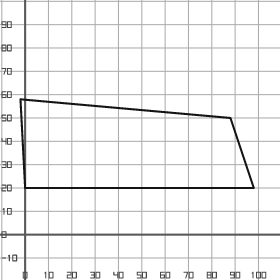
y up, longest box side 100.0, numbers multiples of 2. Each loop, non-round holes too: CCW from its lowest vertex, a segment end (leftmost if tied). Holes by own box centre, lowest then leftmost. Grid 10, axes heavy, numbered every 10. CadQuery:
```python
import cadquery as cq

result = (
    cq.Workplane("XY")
    .moveTo(0.0, 20.0)
    .lineTo(98.0, 20.0)
    .lineTo(88.0, 50.0)
    .lineTo(-2.0, 58.0)
    .close()
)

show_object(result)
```